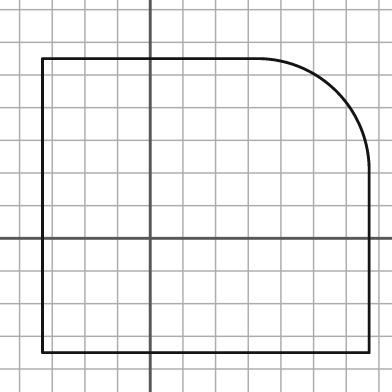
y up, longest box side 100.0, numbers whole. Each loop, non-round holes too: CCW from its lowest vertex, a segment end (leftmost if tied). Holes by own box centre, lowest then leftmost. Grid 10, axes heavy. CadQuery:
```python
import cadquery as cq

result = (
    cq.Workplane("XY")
    .moveTo(-33.0, -35.0)
    .lineTo(67.0, -35.0)
    .lineTo(67.0, 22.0)
    .threePointArc((57.0, 45.0), (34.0, 55.0))
    .lineTo(-33.0, 55.0)
    .close()
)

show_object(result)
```